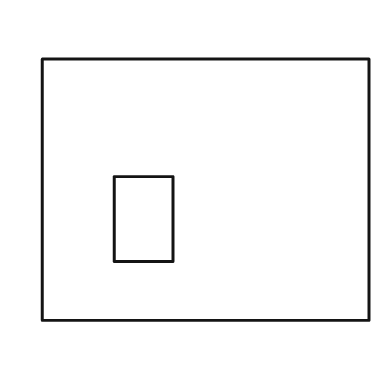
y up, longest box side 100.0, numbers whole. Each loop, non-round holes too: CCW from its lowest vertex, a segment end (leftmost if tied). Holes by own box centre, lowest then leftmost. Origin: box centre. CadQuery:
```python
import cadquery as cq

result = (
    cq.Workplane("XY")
    .moveTo(-50.0, -40.0)
    .lineTo(50.0, -40.0)
    .lineTo(50.0, 40.0)
    .lineTo(-50.0, 40.0)
    .close()
    .moveTo(-28.0, -22.0)
    .lineTo(-10.0, -22.0)
    .lineTo(-10.0, 4.0)
    .lineTo(-28.0, 4.0)
    .close()
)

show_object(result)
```